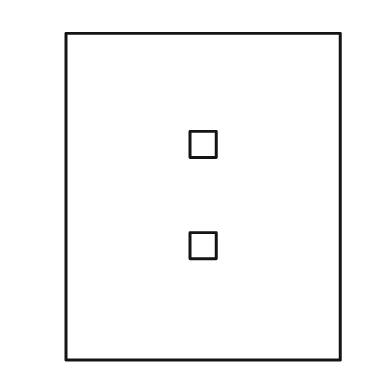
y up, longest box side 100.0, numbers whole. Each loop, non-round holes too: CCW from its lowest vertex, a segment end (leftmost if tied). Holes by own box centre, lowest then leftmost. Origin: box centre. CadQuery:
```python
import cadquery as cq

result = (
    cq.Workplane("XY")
    .moveTo(-42.0, -50.0)
    .lineTo(42.0, -50.0)
    .lineTo(42.0, 50.0)
    .lineTo(-42.0, 50.0)
    .close()
    .moveTo(-4.0, -19.0)
    .lineTo(4.0, -19.0)
    .lineTo(4.0, -11.0)
    .lineTo(-4.0, -11.0)
    .close()
    .moveTo(-4.0, 12.0)
    .lineTo(4.0, 12.0)
    .lineTo(4.0, 20.0)
    .lineTo(-4.0, 20.0)
    .close()
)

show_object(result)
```